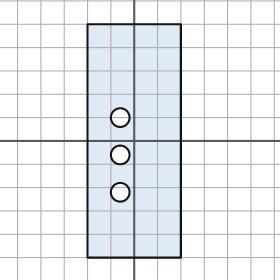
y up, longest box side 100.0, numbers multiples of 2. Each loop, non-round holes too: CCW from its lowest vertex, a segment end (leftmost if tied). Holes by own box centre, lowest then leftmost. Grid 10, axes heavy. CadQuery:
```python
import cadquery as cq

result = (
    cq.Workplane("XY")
    .moveTo(-20.0, -50.0)
    .lineTo(20.0, -50.0)
    .lineTo(20.0, 50.0)
    .lineTo(-20.0, 50.0)
    .close()
    .moveTo(-6.0, -22.0)
    .circle(4.0)
    .moveTo(-6.0, -6.0)
    .circle(4.0)
    .moveTo(-6.0, 10.0)
    .circle(4.0)
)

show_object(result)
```